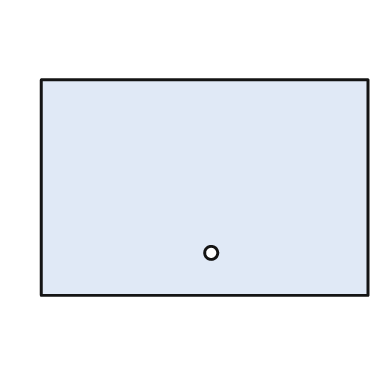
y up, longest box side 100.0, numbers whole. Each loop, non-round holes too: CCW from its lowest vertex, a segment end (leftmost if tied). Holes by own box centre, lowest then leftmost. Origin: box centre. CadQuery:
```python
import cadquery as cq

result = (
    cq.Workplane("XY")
    .moveTo(-50.0, -33.0)
    .lineTo(50.0, -33.0)
    .lineTo(50.0, 33.0)
    .lineTo(-50.0, 33.0)
    .close()
    .moveTo(2.0, -20.0)
    .circle(2.0)
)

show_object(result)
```